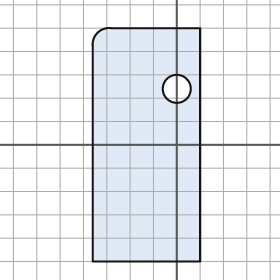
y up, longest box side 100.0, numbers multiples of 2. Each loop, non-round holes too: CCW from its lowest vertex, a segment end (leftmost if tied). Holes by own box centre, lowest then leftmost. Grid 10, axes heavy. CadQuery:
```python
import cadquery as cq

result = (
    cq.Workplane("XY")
    .moveTo(-36.0, -50.0)
    .lineTo(10.0, -50.0)
    .lineTo(10.0, 50.0)
    .lineTo(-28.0, 50.0)
    .threePointArc((-34.0, 48.0), (-36.0, 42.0))
    .close()
    .moveTo(0.0, 24.0)
    .circle(6.0)
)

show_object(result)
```